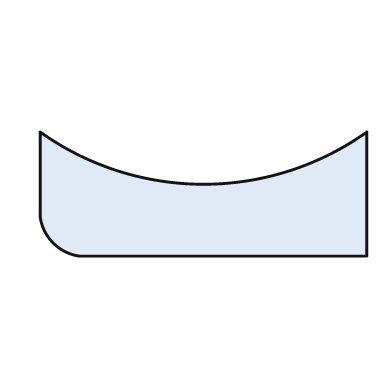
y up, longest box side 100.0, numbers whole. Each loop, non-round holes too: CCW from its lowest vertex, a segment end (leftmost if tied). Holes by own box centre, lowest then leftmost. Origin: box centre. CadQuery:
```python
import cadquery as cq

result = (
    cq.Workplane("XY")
    .moveTo(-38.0, -19.0)
    .lineTo(50.0, -19.0)
    .lineTo(50.0, 19.0)
    .threePointArc((0.0, 3.0), (-50.0, 19.0))
    .lineTo(-50.0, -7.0)
    .threePointArc((-46.0, -15.0), (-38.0, -19.0))
    .close()
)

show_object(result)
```